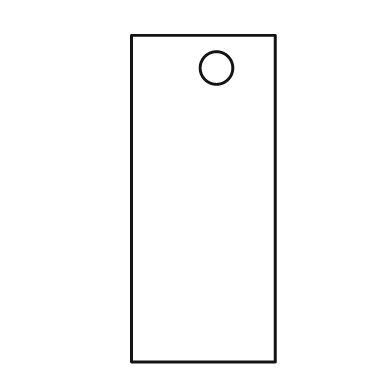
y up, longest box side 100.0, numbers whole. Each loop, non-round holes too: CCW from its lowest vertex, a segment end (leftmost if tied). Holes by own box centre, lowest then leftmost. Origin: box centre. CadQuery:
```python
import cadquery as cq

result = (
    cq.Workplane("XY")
    .moveTo(-22.0, -50.0)
    .lineTo(22.0, -50.0)
    .lineTo(22.0, 50.0)
    .lineTo(-22.0, 50.0)
    .close()
    .moveTo(4.0, 40.0)
    .circle(5.0)
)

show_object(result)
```